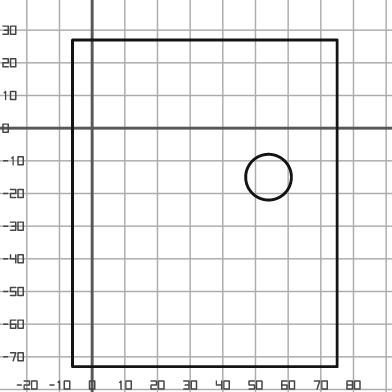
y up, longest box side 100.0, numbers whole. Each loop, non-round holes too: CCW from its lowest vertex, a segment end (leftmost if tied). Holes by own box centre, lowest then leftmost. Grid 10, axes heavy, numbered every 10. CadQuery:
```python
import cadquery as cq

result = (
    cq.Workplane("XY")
    .moveTo(-6.0, -73.0)
    .lineTo(75.0, -73.0)
    .lineTo(75.0, 27.0)
    .lineTo(-6.0, 27.0)
    .close()
    .moveTo(54.0, -15.0)
    .circle(7.0)
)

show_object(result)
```